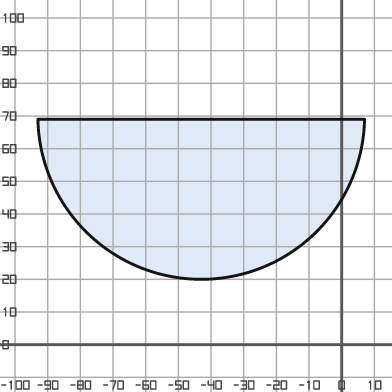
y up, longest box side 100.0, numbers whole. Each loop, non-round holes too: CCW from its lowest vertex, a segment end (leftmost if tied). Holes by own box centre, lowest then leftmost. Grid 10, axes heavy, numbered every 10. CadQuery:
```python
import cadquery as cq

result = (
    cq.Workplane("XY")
    .moveTo(-93.0, 69.0)
    .threePointArc((-43.0, 20.0), (7.0, 69.0))
    .close()
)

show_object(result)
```